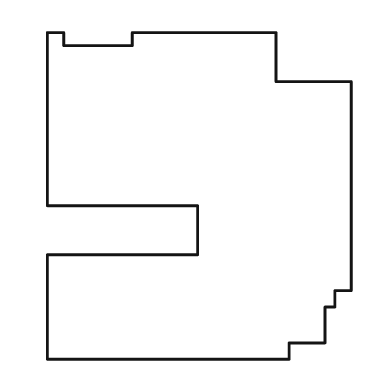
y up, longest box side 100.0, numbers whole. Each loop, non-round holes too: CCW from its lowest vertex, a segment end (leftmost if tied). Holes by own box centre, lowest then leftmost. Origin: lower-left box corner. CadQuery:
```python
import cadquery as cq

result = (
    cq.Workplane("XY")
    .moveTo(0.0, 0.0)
    .lineTo(74.0, 0.0)
    .lineTo(74.0, 5.0)
    .lineTo(85.0, 5.0)
    .lineTo(85.0, 16.0)
    .lineTo(88.0, 16.0)
    .lineTo(88.0, 21.0)
    .lineTo(93.0, 21.0)
    .lineTo(93.0, 85.0)
    .lineTo(70.0, 85.0)
    .lineTo(70.0, 100.0)
    .lineTo(26.0, 100.0)
    .lineTo(26.0, 96.0)
    .lineTo(5.0, 96.0)
    .lineTo(5.0, 100.0)
    .lineTo(0.0, 100.0)
    .lineTo(0.0, 47.0)
    .lineTo(46.0, 47.0)
    .lineTo(46.0, 32.0)
    .lineTo(0.0, 32.0)
    .close()
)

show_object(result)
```